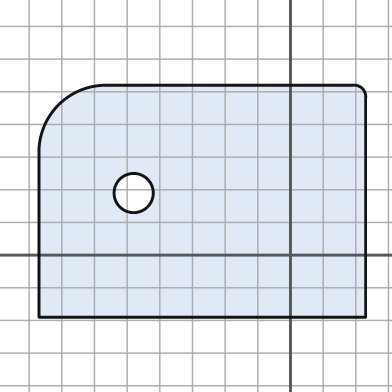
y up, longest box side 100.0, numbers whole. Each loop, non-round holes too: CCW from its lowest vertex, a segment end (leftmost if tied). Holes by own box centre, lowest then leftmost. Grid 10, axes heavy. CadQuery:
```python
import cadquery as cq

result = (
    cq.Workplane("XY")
    .moveTo(-77.0, -19.0)
    .lineTo(23.0, -19.0)
    .lineTo(23.0, 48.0)
    .threePointArc((22.0, 51.0), (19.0, 52.0))
    .lineTo(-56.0, 52.0)
    .threePointArc((-71.0, 46.0), (-77.0, 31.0))
    .close()
    .moveTo(-48.0, 19.0)
    .circle(6.0)
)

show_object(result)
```